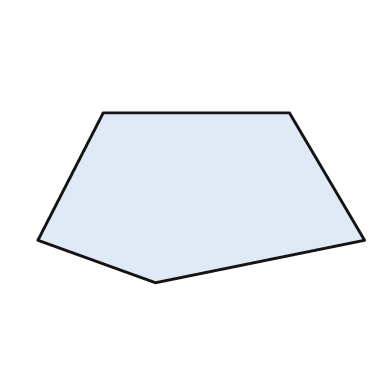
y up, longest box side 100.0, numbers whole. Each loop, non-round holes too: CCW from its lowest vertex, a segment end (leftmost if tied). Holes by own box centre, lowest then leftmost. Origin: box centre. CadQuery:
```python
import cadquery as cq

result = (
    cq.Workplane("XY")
    .moveTo(-14.0, -26.0)
    .lineTo(50.0, -13.0)
    .lineTo(27.0, 26.0)
    .lineTo(-30.0, 26.0)
    .lineTo(-50.0, -13.0)
    .close()
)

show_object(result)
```